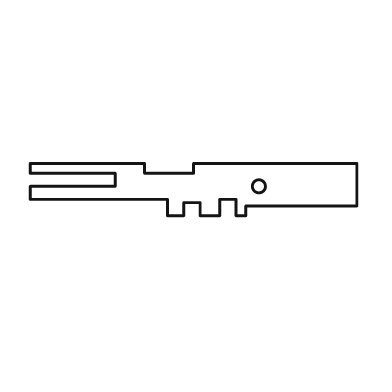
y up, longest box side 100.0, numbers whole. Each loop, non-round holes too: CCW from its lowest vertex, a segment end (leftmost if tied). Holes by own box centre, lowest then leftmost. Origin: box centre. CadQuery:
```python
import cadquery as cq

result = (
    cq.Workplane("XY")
    .moveTo(-8.0, -8.0)
    .lineTo(-3.0, -8.0)
    .lineTo(-3.0, -4.0)
    .lineTo(2.0, -4.0)
    .lineTo(2.0, -8.0)
    .lineTo(8.0, -8.0)
    .lineTo(8.0, -3.0)
    .lineTo(13.0, -3.0)
    .lineTo(13.0, -8.0)
    .lineTo(16.0, -8.0)
    .lineTo(16.0, -5.0)
    .lineTo(50.0, -5.0)
    .lineTo(50.0, 8.0)
    .lineTo(0.0, 8.0)
    .lineTo(0.0, 5.0)
    .lineTo(-15.0, 5.0)
    .lineTo(-15.0, 8.0)
    .lineTo(-50.0, 8.0)
    .lineTo(-50.0, 5.0)
    .lineTo(-24.0, 5.0)
    .lineTo(-24.0, 1.0)
    .lineTo(-50.0, 1.0)
    .lineTo(-50.0, -3.0)
    .lineTo(-8.0, -3.0)
    .close()
    .moveTo(20.0, 1.0)
    .circle(2.0)
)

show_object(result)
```